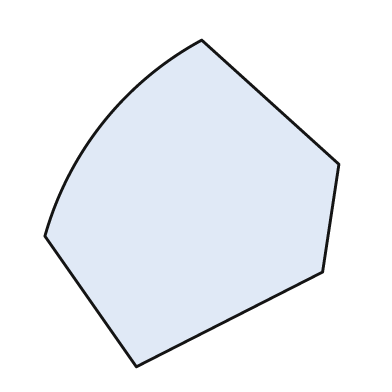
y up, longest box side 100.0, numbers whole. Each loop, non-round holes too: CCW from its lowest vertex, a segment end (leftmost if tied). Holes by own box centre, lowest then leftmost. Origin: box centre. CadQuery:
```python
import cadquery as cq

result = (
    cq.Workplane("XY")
    .moveTo(-17.0, -50.0)
    .lineTo(40.0, -21.0)
    .lineTo(45.0, 12.0)
    .lineTo(3.0, 50.0)
    .threePointArc((-27.0, 25.0), (-45.0, -10.0))
    .close()
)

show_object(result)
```